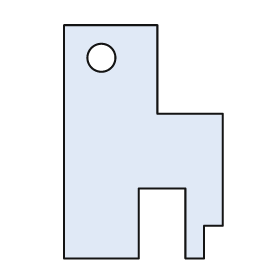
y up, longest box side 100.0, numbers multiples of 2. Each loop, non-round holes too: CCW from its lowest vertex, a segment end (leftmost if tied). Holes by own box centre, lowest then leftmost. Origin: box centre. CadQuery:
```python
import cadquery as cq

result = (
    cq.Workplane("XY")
    .moveTo(-34.0, -50.0)
    .lineTo(-2.0, -50.0)
    .lineTo(-2.0, -20.0)
    .lineTo(18.0, -20.0)
    .lineTo(18.0, -50.0)
    .lineTo(26.0, -50.0)
    .lineTo(26.0, -36.0)
    .lineTo(34.0, -36.0)
    .lineTo(34.0, 12.0)
    .lineTo(6.0, 12.0)
    .lineTo(6.0, 50.0)
    .lineTo(-34.0, 50.0)
    .close()
    .moveTo(-18.0, 36.0)
    .circle(6.0)
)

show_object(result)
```